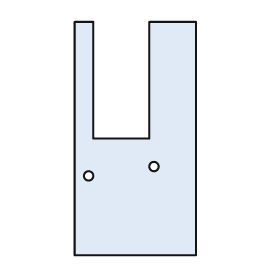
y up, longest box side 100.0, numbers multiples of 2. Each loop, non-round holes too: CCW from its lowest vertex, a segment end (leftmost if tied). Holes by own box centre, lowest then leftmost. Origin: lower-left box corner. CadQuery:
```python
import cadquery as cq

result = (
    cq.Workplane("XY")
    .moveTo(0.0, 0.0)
    .lineTo(52.0, 0.0)
    .lineTo(52.0, 100.0)
    .lineTo(32.0, 100.0)
    .lineTo(32.0, 50.0)
    .lineTo(8.0, 50.0)
    .lineTo(8.0, 100.0)
    .lineTo(0.0, 100.0)
    .close()
    .moveTo(6.0, 34.0)
    .circle(2.0)
    .moveTo(34.0, 38.0)
    .circle(2.0)
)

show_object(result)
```